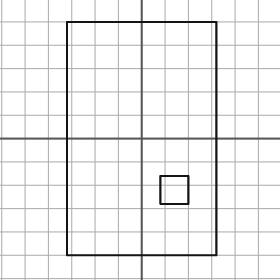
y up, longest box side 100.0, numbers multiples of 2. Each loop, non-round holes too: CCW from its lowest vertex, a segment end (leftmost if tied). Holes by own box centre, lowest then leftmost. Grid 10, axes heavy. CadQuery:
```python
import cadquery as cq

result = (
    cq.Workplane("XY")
    .moveTo(-32.0, -50.0)
    .lineTo(32.0, -50.0)
    .lineTo(32.0, 50.0)
    .lineTo(-32.0, 50.0)
    .close()
    .moveTo(8.0, -28.0)
    .lineTo(20.0, -28.0)
    .lineTo(20.0, -16.0)
    .lineTo(8.0, -16.0)
    .close()
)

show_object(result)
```